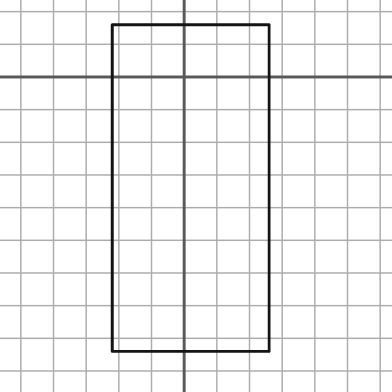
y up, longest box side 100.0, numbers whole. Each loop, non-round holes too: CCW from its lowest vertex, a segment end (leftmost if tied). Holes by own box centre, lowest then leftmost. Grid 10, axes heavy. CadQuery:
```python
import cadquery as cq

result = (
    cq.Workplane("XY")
    .moveTo(-22.0, -84.0)
    .lineTo(26.0, -84.0)
    .lineTo(26.0, 16.0)
    .lineTo(-22.0, 16.0)
    .close()
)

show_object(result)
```